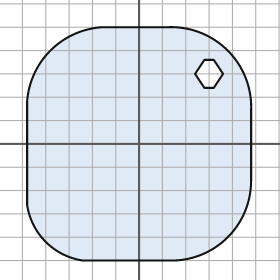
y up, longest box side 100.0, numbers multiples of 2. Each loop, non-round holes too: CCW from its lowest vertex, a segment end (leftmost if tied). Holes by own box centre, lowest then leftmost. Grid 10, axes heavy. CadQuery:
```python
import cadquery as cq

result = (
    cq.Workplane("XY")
    .moveTo(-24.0, -50.0)
    .lineTo(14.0, -50.0)
    .threePointArc((38.0, -40.0), (48.0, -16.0))
    .lineTo(48.0, 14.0)
    .threePointArc((38.0, 40.0), (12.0, 50.0))
    .lineTo(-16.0, 50.0)
    .threePointArc((-38.0, 40.0), (-48.0, 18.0))
    .lineTo(-48.0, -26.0)
    .threePointArc((-40.0, -42.0), (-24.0, -50.0))
    .close()
    .moveTo(28.0, 24.0)
    .lineTo(32.0, 24.0)
    .lineTo(36.0, 30.0)
    .lineTo(32.0, 36.0)
    .lineTo(28.0, 36.0)
    .lineTo(24.0, 30.0)
    .close()
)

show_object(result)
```